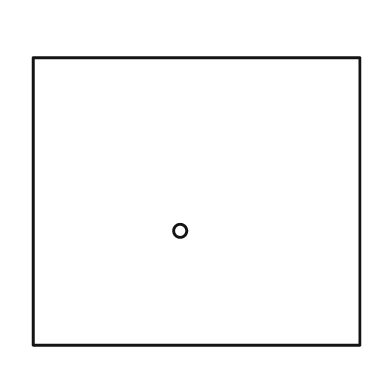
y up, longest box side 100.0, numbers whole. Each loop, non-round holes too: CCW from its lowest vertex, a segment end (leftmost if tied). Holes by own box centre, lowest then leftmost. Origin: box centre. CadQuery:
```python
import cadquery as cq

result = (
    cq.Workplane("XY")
    .moveTo(-50.0, -44.0)
    .lineTo(50.0, -44.0)
    .lineTo(50.0, 44.0)
    .lineTo(-50.0, 44.0)
    .close()
    .moveTo(-5.0, -9.0)
    .circle(2.0)
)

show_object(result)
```